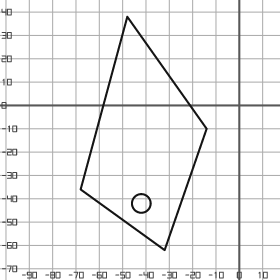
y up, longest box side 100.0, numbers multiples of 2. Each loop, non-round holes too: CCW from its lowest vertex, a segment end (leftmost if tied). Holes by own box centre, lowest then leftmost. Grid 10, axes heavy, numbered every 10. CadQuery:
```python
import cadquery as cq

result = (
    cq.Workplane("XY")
    .moveTo(-32.0, -62.0)
    .lineTo(-14.0, -10.0)
    .lineTo(-48.0, 38.0)
    .lineTo(-68.0, -36.0)
    .close()
    .moveTo(-42.0, -42.0)
    .circle(4.0)
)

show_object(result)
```